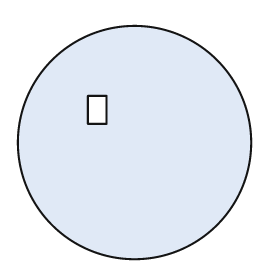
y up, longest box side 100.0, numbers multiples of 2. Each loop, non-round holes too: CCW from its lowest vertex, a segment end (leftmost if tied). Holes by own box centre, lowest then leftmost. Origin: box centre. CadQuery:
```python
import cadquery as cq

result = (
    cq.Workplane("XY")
    .moveTo(0.0, 0.0)
    .circle(50.0)
    .moveTo(-20.0, 8.0)
    .lineTo(-12.0, 8.0)
    .lineTo(-12.0, 20.0)
    .lineTo(-20.0, 20.0)
    .close()
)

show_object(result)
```